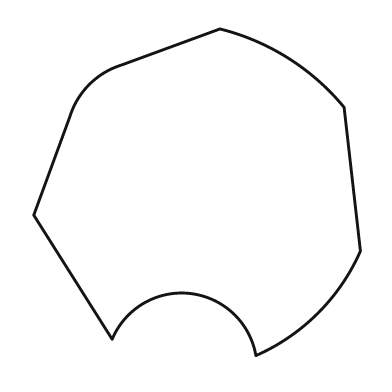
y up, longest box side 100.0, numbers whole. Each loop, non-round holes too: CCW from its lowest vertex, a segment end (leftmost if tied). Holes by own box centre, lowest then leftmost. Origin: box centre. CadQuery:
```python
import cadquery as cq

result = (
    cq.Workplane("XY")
    .moveTo(18.0, -50.0)
    .threePointArc((37.0, -37.0), (50.0, -18.0))
    .lineTo(45.0, 26.0)
    .threePointArc((28.0, 41.0), (7.0, 50.0))
    .lineTo(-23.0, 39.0)
    .threePointArc((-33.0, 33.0), (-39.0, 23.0))
    .lineTo(-50.0, -7.0)
    .lineTo(-26.0, -45.0)
    .threePointArc((-2.0, -31.0), (18.0, -50.0))
    .close()
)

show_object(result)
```